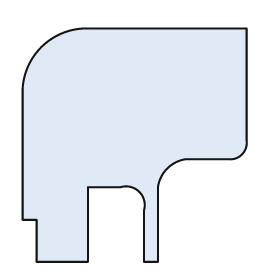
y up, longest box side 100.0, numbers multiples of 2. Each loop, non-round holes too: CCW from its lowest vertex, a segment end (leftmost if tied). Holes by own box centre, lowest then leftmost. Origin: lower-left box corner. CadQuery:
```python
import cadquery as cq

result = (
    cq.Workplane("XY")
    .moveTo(6.0, 0.0)
    .lineTo(28.0, 0.0)
    .lineTo(28.0, 32.0)
    .lineTo(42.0, 32.0)
    .threePointArc((50.0, 30.0), (52.0, 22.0))
    .lineTo(52.0, 0.0)
    .lineTo(58.0, 0.0)
    .lineTo(58.0, 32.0)
    .threePointArc((62.0, 40.0), (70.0, 44.0))
    .lineTo(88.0, 44.0)
    .threePointArc((94.0, 46.0), (96.0, 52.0))
    .lineTo(96.0, 100.0)
    .lineTo(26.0, 100.0)
    .threePointArc((8.0, 92.0), (0.0, 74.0))
    .lineTo(0.0, 18.0)
    .lineTo(6.0, 18.0)
    .close()
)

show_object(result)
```